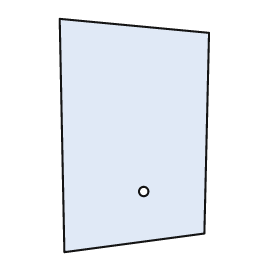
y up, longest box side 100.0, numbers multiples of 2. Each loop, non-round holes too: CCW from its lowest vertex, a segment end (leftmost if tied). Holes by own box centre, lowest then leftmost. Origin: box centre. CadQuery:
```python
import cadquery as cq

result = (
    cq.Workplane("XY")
    .moveTo(-30.0, -50.0)
    .lineTo(30.0, -42.0)
    .lineTo(32.0, 44.0)
    .lineTo(-32.0, 50.0)
    .close()
    .moveTo(4.0, -24.0)
    .circle(2.0)
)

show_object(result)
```